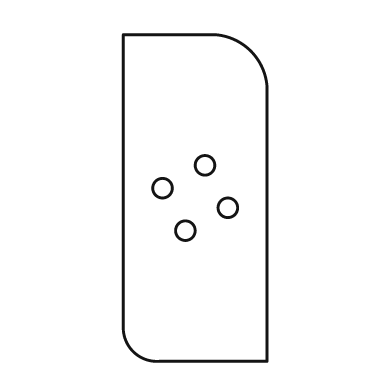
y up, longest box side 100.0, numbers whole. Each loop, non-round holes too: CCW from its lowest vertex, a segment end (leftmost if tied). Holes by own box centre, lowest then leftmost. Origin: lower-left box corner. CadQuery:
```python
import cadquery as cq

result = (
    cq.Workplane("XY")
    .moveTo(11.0, 0.0)
    .lineTo(44.0, 0.0)
    .lineTo(44.0, 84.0)
    .threePointArc((39.0, 95.0), (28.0, 100.0))
    .lineTo(0.0, 100.0)
    .lineTo(0.0, 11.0)
    .threePointArc((3.0, 3.0), (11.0, 0.0))
    .close()
    .moveTo(19.0, 40.0)
    .circle(3.0)
    .moveTo(32.0, 47.0)
    .circle(3.0)
    .moveTo(12.0, 53.0)
    .circle(3.0)
    .moveTo(25.0, 60.0)
    .circle(3.0)
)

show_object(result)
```